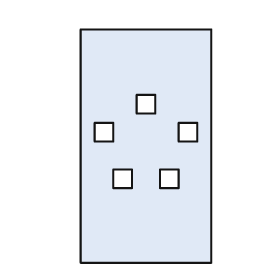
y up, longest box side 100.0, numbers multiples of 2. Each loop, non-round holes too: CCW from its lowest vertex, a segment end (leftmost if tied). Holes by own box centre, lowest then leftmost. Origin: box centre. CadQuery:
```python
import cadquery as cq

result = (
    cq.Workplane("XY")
    .moveTo(-28.0, -50.0)
    .lineTo(28.0, -50.0)
    .lineTo(28.0, 50.0)
    .lineTo(-28.0, 50.0)
    .close()
    .moveTo(-14.0, -18.0)
    .lineTo(-6.0, -18.0)
    .lineTo(-6.0, -10.0)
    .lineTo(-14.0, -10.0)
    .close()
    .moveTo(6.0, -18.0)
    .lineTo(14.0, -18.0)
    .lineTo(14.0, -10.0)
    .lineTo(6.0, -10.0)
    .close()
    .moveTo(-22.0, 2.0)
    .lineTo(-14.0, 2.0)
    .lineTo(-14.0, 10.0)
    .lineTo(-22.0, 10.0)
    .close()
    .moveTo(14.0, 2.0)
    .lineTo(22.0, 2.0)
    .lineTo(22.0, 10.0)
    .lineTo(14.0, 10.0)
    .close()
    .moveTo(-4.0, 14.0)
    .lineTo(4.0, 14.0)
    .lineTo(4.0, 22.0)
    .lineTo(-4.0, 22.0)
    .close()
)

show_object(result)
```